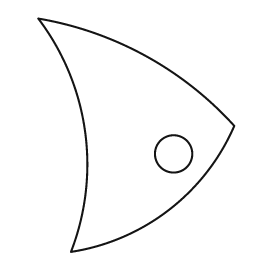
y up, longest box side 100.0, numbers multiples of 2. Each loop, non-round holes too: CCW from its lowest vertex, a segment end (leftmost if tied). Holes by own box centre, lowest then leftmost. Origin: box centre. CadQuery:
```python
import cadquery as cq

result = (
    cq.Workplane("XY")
    .moveTo(-28.0, -50.0)
    .threePointArc((14.0, -32.0), (42.0, 4.0))
    .threePointArc((4.0, 34.0), (-42.0, 50.0))
    .threePointArc((-22.0, 2.0), (-28.0, -50.0))
    .close()
    .moveTo(16.0, -8.0)
    .circle(8.0)
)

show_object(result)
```